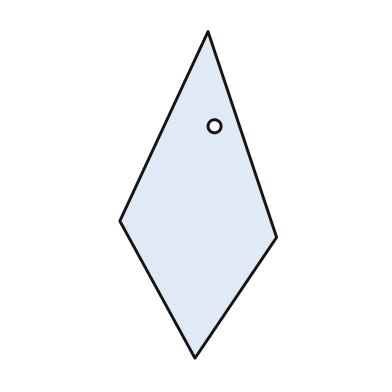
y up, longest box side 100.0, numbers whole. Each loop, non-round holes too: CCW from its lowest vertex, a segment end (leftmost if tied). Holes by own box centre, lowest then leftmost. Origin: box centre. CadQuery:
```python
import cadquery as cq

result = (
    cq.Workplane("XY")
    .moveTo(-1.0, -50.0)
    .lineTo(24.0, -13.0)
    .lineTo(3.0, 50.0)
    .lineTo(-24.0, -8.0)
    .close()
    .moveTo(5.0, 21.0)
    .circle(2.0)
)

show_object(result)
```